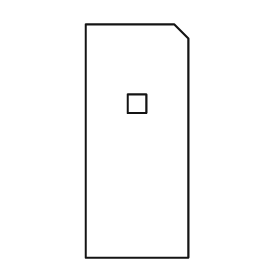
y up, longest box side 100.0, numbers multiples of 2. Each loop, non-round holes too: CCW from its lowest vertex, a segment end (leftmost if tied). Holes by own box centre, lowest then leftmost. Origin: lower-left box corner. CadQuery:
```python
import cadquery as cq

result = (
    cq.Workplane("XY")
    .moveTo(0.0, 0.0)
    .lineTo(44.0, 0.0)
    .lineTo(44.0, 94.0)
    .lineTo(38.0, 100.0)
    .lineTo(0.0, 100.0)
    .close()
    .moveTo(18.0, 62.0)
    .lineTo(26.0, 62.0)
    .lineTo(26.0, 70.0)
    .lineTo(18.0, 70.0)
    .close()
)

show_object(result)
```